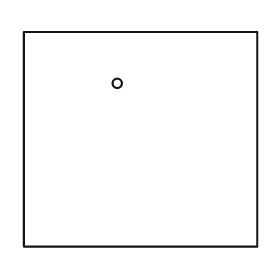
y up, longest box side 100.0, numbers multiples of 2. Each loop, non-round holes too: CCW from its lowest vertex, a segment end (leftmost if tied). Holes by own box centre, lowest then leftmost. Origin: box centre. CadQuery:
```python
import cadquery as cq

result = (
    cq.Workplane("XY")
    .moveTo(-50.0, -46.0)
    .lineTo(50.0, -46.0)
    .lineTo(50.0, 46.0)
    .lineTo(-50.0, 46.0)
    .close()
    .moveTo(-10.0, 24.0)
    .circle(2.0)
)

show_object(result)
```